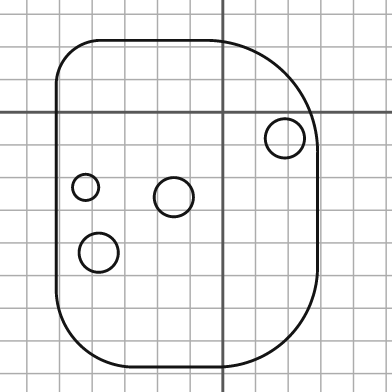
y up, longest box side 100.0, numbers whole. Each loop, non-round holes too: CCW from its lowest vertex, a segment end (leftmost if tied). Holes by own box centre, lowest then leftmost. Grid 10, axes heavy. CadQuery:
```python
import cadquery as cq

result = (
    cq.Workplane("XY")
    .moveTo(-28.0, -78.0)
    .lineTo(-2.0, -78.0)
    .threePointArc((20.0, -69.0), (29.0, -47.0))
    .lineTo(29.0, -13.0)
    .threePointArc((19.0, 12.0), (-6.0, 22.0))
    .lineTo(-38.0, 22.0)
    .threePointArc((-47.0, 18.0), (-51.0, 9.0))
    .lineTo(-51.0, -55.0)
    .threePointArc((-44.0, -71.0), (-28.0, -78.0))
    .close()
    .moveTo(-38.0, -43.0)
    .circle(6.0)
    .moveTo(-15.0, -26.0)
    .circle(6.0)
    .moveTo(-42.0, -23.0)
    .circle(4.0)
    .moveTo(19.0, -8.0)
    .circle(6.0)
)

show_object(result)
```